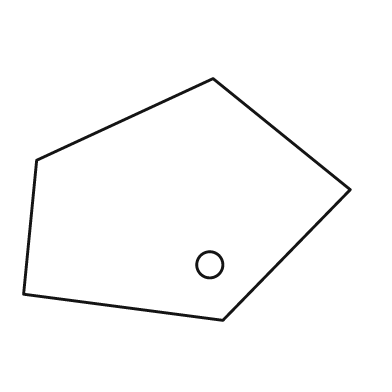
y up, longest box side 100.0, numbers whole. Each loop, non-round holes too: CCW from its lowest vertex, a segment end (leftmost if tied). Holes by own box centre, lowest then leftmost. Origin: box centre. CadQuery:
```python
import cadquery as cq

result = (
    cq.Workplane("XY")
    .moveTo(11.0, -37.0)
    .lineTo(50.0, 3.0)
    .lineTo(8.0, 37.0)
    .lineTo(-46.0, 12.0)
    .lineTo(-50.0, -29.0)
    .close()
    .moveTo(7.0, -20.0)
    .circle(4.0)
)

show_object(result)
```